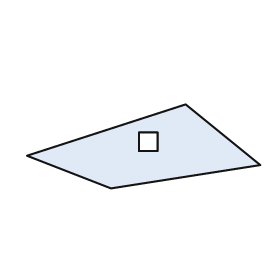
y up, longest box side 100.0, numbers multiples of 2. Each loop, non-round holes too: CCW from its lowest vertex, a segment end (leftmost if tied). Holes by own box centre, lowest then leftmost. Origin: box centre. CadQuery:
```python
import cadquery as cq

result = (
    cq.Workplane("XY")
    .moveTo(-14.0, -18.0)
    .lineTo(50.0, -8.0)
    .lineTo(18.0, 18.0)
    .lineTo(-50.0, -4.0)
    .close()
    .moveTo(-2.0, -2.0)
    .lineTo(6.0, -2.0)
    .lineTo(6.0, 6.0)
    .lineTo(-2.0, 6.0)
    .close()
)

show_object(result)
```